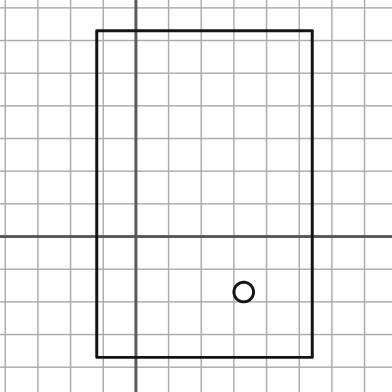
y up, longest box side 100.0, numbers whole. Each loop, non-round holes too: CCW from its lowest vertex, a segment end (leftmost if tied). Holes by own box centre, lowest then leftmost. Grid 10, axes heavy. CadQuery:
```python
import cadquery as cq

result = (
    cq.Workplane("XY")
    .moveTo(-12.0, -37.0)
    .lineTo(54.0, -37.0)
    .lineTo(54.0, 63.0)
    .lineTo(-12.0, 63.0)
    .close()
    .moveTo(33.0, -17.0)
    .circle(3.0)
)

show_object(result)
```